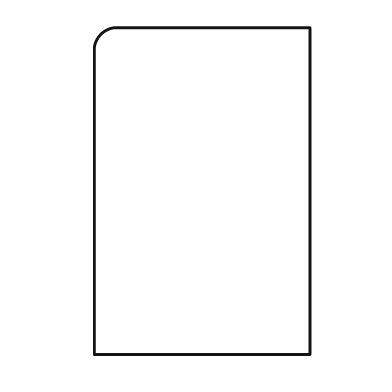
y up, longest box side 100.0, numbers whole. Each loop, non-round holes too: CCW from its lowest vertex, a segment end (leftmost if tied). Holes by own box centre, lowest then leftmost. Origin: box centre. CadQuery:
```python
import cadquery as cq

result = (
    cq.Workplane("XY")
    .moveTo(-33.0, -50.0)
    .lineTo(33.0, -50.0)
    .lineTo(33.0, 50.0)
    .lineTo(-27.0, 50.0)
    .threePointArc((-31.0, 48.0), (-33.0, 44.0))
    .close()
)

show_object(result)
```